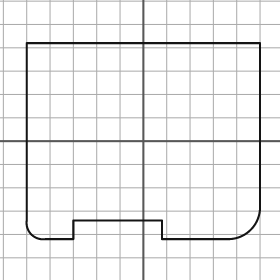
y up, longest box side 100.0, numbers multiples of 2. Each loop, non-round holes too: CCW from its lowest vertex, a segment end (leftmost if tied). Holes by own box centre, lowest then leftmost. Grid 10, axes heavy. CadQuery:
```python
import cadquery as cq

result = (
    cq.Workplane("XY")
    .moveTo(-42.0, -42.0)
    .lineTo(-30.0, -42.0)
    .lineTo(-30.0, -34.0)
    .lineTo(8.0, -34.0)
    .lineTo(8.0, -42.0)
    .lineTo(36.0, -42.0)
    .threePointArc((46.0, -38.0), (50.0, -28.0))
    .lineTo(50.0, 42.0)
    .lineTo(-50.0, 42.0)
    .lineTo(-50.0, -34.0)
    .threePointArc((-48.0, -40.0), (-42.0, -42.0))
    .close()
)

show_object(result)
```